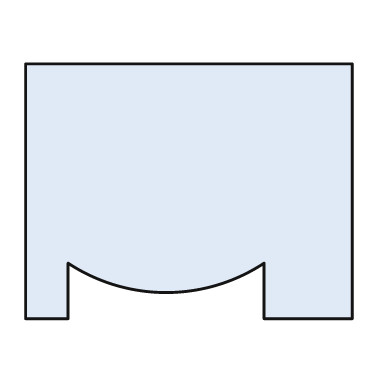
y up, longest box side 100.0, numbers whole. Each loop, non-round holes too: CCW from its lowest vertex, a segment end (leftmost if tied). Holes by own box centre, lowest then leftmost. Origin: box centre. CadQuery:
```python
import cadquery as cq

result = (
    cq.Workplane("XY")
    .moveTo(-50.0, -39.0)
    .lineTo(-37.0, -39.0)
    .lineTo(-37.0, -22.0)
    .threePointArc((-7.0, -31.0), (23.0, -22.0))
    .lineTo(23.0, -39.0)
    .lineTo(50.0, -39.0)
    .lineTo(50.0, 39.0)
    .lineTo(-50.0, 39.0)
    .close()
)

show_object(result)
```